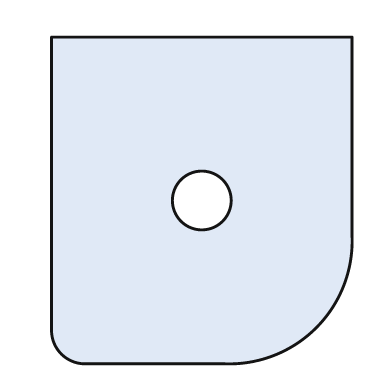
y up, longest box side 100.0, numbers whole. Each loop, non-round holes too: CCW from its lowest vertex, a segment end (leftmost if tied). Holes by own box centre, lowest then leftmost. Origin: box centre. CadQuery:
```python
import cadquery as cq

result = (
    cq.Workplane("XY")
    .moveTo(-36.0, -50.0)
    .lineTo(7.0, -50.0)
    .threePointArc((35.0, -39.0), (46.0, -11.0))
    .lineTo(46.0, 50.0)
    .lineTo(-46.0, 50.0)
    .lineTo(-46.0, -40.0)
    .threePointArc((-43.0, -47.0), (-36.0, -50.0))
    .close()
    .moveTo(0.0, 0.0)
    .circle(9.0)
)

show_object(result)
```